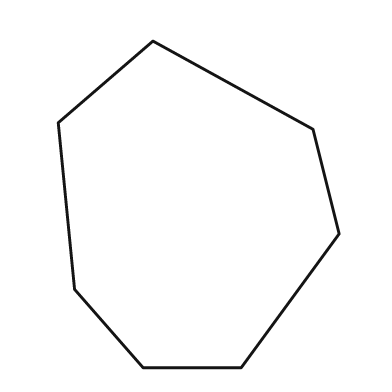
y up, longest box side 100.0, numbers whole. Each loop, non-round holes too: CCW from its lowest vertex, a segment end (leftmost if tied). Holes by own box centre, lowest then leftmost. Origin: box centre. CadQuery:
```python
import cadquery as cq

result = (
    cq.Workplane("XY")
    .moveTo(-17.0, -50.0)
    .lineTo(13.0, -50.0)
    .lineTo(43.0, -9.0)
    .lineTo(35.0, 23.0)
    .lineTo(-14.0, 50.0)
    .lineTo(-43.0, 25.0)
    .lineTo(-38.0, -26.0)
    .close()
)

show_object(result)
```